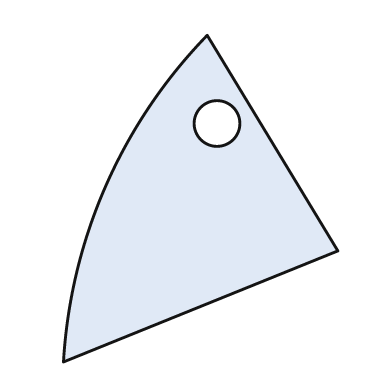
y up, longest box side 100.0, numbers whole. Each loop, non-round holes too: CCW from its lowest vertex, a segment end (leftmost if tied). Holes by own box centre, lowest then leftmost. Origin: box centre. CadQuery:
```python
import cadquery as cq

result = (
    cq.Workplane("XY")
    .moveTo(-42.0, -50.0)
    .lineTo(42.0, -16.0)
    .lineTo(2.0, 50.0)
    .threePointArc((-29.0, 4.0), (-42.0, -50.0))
    .close()
    .moveTo(5.0, 23.0)
    .circle(7.0)
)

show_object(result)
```